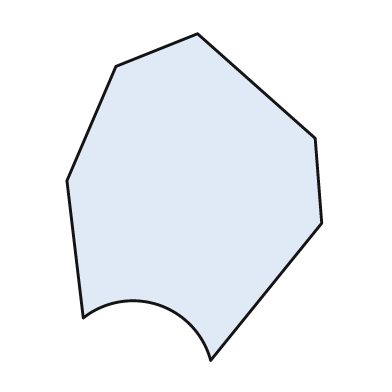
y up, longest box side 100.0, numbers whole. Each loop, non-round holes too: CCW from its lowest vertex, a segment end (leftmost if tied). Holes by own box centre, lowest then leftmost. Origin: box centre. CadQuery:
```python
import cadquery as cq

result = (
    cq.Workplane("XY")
    .moveTo(5.0, -50.0)
    .lineTo(39.0, -8.0)
    .lineTo(37.0, 18.0)
    .lineTo(1.0, 50.0)
    .lineTo(-24.0, 40.0)
    .lineTo(-39.0, 5.0)
    .lineTo(-34.0, -37.0)
    .threePointArc((-11.0, -33.0), (5.0, -50.0))
    .close()
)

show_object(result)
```